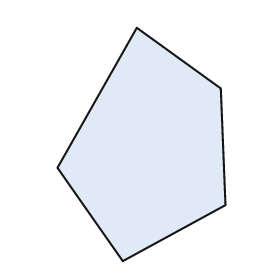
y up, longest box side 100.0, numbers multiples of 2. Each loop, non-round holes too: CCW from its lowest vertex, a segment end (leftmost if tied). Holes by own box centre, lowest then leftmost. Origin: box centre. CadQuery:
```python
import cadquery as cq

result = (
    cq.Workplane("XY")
    .moveTo(-8.0, -50.0)
    .lineTo(36.0, -26.0)
    .lineTo(34.0, 24.0)
    .lineTo(-2.0, 50.0)
    .lineTo(-36.0, -10.0)
    .close()
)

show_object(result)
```